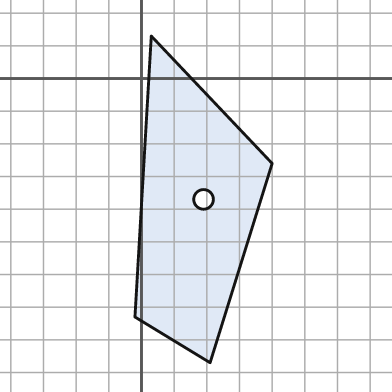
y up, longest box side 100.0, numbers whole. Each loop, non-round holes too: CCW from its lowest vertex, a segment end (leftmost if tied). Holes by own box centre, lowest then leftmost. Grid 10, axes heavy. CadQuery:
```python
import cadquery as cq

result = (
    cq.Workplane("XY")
    .moveTo(21.0, -87.0)
    .lineTo(40.0, -26.0)
    .lineTo(3.0, 13.0)
    .lineTo(-2.0, -73.0)
    .close()
    .moveTo(19.0, -37.0)
    .circle(3.0)
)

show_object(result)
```